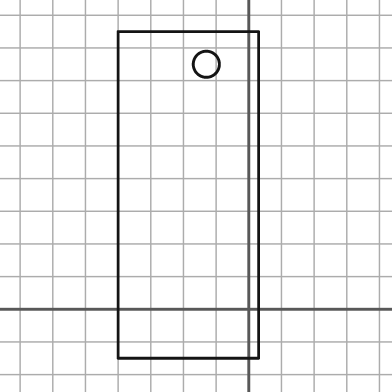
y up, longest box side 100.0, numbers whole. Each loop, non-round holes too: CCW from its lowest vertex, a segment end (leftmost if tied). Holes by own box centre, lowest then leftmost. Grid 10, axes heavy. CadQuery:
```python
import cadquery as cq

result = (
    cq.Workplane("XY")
    .moveTo(-40.0, -15.0)
    .lineTo(3.0, -15.0)
    .lineTo(3.0, 85.0)
    .lineTo(-40.0, 85.0)
    .close()
    .moveTo(-13.0, 75.0)
    .circle(4.0)
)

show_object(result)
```